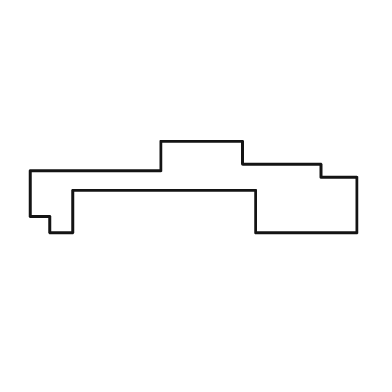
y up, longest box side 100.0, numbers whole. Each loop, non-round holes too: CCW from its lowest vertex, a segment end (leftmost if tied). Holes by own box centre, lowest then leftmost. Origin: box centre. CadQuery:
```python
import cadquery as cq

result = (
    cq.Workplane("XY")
    .moveTo(-44.0, -14.0)
    .lineTo(-37.0, -14.0)
    .lineTo(-37.0, -1.0)
    .lineTo(19.0, -1.0)
    .lineTo(19.0, -14.0)
    .lineTo(50.0, -14.0)
    .lineTo(50.0, 3.0)
    .lineTo(39.0, 3.0)
    .lineTo(39.0, 7.0)
    .lineTo(15.0, 7.0)
    .lineTo(15.0, 14.0)
    .lineTo(-10.0, 14.0)
    .lineTo(-10.0, 5.0)
    .lineTo(-50.0, 5.0)
    .lineTo(-50.0, -9.0)
    .lineTo(-44.0, -9.0)
    .close()
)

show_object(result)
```